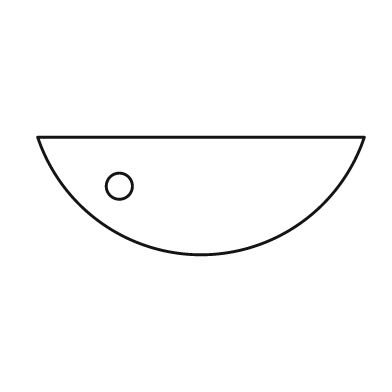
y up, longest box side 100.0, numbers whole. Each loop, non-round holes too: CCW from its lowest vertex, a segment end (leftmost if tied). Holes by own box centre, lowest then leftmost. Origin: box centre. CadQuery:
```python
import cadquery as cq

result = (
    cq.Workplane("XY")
    .moveTo(-50.0, 18.0)
    .threePointArc((0.0, -18.0), (50.0, 18.0))
    .close()
    .moveTo(-25.0, 3.0)
    .circle(4.0)
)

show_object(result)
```